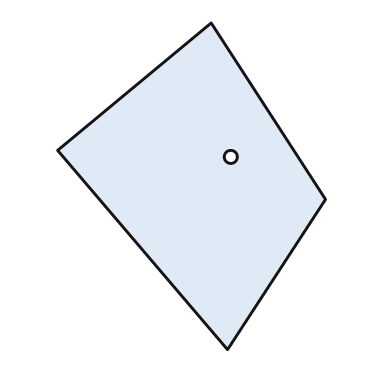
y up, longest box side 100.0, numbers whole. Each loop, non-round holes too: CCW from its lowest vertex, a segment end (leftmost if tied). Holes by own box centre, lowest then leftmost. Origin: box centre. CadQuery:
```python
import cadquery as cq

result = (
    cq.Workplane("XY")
    .moveTo(11.0, -50.0)
    .lineTo(41.0, -4.0)
    .lineTo(6.0, 50.0)
    .lineTo(-41.0, 11.0)
    .close()
    .moveTo(12.0, 9.0)
    .circle(2.0)
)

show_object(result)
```